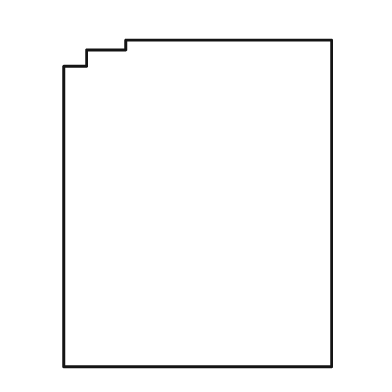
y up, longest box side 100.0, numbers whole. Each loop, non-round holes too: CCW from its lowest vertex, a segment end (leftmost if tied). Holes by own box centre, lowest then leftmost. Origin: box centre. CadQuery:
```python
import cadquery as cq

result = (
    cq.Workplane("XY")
    .moveTo(-41.0, -50.0)
    .lineTo(41.0, -50.0)
    .lineTo(41.0, 50.0)
    .lineTo(-22.0, 50.0)
    .lineTo(-22.0, 47.0)
    .lineTo(-34.0, 47.0)
    .lineTo(-34.0, 42.0)
    .lineTo(-41.0, 42.0)
    .close()
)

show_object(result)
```